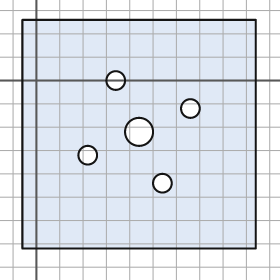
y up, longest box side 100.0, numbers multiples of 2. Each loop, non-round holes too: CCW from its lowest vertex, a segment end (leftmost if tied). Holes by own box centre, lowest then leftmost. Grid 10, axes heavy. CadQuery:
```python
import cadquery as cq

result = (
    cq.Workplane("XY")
    .moveTo(-6.0, -72.0)
    .lineTo(94.0, -72.0)
    .lineTo(94.0, 26.0)
    .lineTo(-6.0, 26.0)
    .close()
    .moveTo(54.0, -44.0)
    .circle(4.0)
    .moveTo(22.0, -32.0)
    .circle(4.0)
    .moveTo(44.0, -22.0)
    .circle(6.0)
    .moveTo(66.0, -12.0)
    .circle(4.0)
    .moveTo(34.0, 0.0)
    .circle(4.0)
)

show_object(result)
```